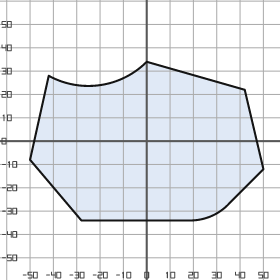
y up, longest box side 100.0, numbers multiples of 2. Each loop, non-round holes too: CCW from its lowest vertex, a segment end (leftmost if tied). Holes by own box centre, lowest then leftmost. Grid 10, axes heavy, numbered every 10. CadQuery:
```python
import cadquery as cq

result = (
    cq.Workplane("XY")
    .moveTo(-28.0, -34.0)
    .lineTo(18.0, -34.0)
    .threePointArc((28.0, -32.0), (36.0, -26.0))
    .lineTo(50.0, -12.0)
    .lineTo(42.0, 22.0)
    .lineTo(0.0, 34.0)
    .threePointArc((-20.0, 24.0), (-42.0, 28.0))
    .lineTo(-50.0, -8.0)
    .close()
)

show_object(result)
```